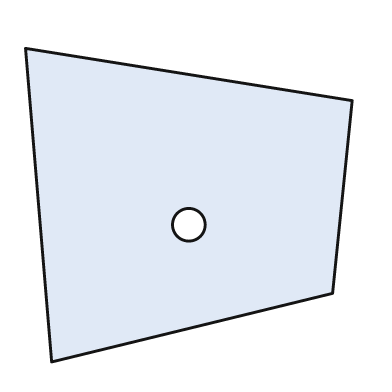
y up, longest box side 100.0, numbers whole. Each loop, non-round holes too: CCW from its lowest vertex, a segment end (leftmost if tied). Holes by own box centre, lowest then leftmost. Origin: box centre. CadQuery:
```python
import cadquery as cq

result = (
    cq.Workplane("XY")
    .moveTo(-42.0, -48.0)
    .lineTo(44.0, -27.0)
    .lineTo(50.0, 32.0)
    .lineTo(-50.0, 48.0)
    .close()
    .moveTo(0.0, -6.0)
    .circle(5.0)
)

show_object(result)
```